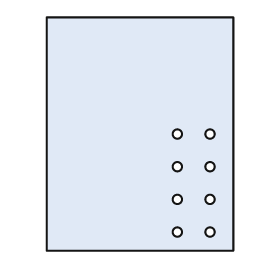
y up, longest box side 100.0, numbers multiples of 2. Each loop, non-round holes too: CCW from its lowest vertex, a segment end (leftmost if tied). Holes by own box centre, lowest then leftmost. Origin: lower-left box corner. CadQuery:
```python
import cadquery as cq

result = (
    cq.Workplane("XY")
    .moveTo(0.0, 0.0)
    .lineTo(80.0, 0.0)
    .lineTo(80.0, 100.0)
    .lineTo(0.0, 100.0)
    .close()
    .moveTo(56.0, 8.0)
    .circle(2.0)
    .moveTo(70.0, 8.0)
    .circle(2.0)
    .moveTo(56.0, 22.0)
    .circle(2.0)
    .moveTo(70.0, 22.0)
    .circle(2.0)
    .moveTo(56.0, 36.0)
    .circle(2.0)
    .moveTo(70.0, 36.0)
    .circle(2.0)
    .moveTo(56.0, 50.0)
    .circle(2.0)
    .moveTo(70.0, 50.0)
    .circle(2.0)
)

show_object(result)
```